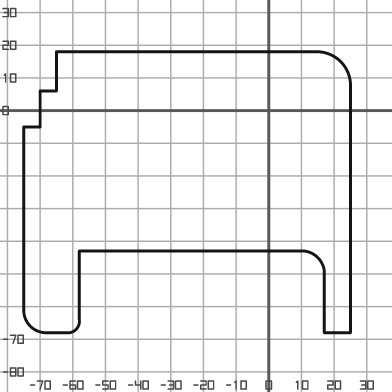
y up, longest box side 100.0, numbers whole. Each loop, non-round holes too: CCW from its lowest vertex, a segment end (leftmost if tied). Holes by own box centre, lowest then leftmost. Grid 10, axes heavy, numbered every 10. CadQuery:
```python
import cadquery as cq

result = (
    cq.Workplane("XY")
    .moveTo(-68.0, -68.0)
    .lineTo(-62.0, -68.0)
    .threePointArc((-59.0, -67.0), (-58.0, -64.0))
    .lineTo(-58.0, -43.0)
    .lineTo(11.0, -43.0)
    .threePointArc((15.0, -45.0), (17.0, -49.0))
    .lineTo(17.0, -68.0)
    .lineTo(25.0, -68.0)
    .lineTo(25.0, 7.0)
    .threePointArc((22.0, 15.0), (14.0, 18.0))
    .lineTo(-65.0, 18.0)
    .lineTo(-65.0, 6.0)
    .lineTo(-70.0, 6.0)
    .lineTo(-70.0, -5.0)
    .lineTo(-75.0, -5.0)
    .lineTo(-75.0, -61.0)
    .threePointArc((-73.0, -66.0), (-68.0, -68.0))
    .close()
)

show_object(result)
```